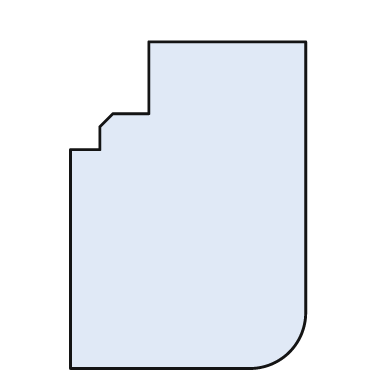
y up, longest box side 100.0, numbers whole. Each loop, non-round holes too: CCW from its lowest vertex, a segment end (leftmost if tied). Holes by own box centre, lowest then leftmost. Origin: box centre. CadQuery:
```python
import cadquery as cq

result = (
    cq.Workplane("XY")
    .moveTo(-36.0, -50.0)
    .lineTo(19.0, -50.0)
    .threePointArc((31.0, -45.0), (36.0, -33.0))
    .lineTo(36.0, 50.0)
    .lineTo(-12.0, 50.0)
    .lineTo(-12.0, 28.0)
    .lineTo(-23.0, 28.0)
    .lineTo(-27.0, 24.0)
    .lineTo(-27.0, 17.0)
    .lineTo(-36.0, 17.0)
    .close()
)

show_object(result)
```